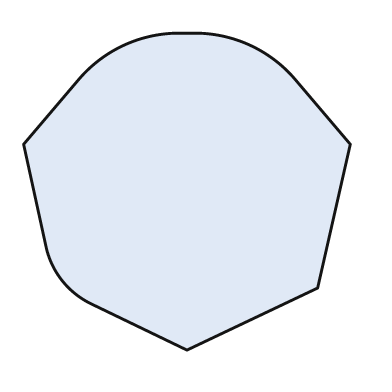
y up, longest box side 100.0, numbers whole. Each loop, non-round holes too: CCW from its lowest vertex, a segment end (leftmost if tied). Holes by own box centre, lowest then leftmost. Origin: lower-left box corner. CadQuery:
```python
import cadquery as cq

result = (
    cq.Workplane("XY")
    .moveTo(50.0, 0.0)
    .lineTo(90.0, 19.0)
    .lineTo(100.0, 63.0)
    .lineTo(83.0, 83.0)
    .threePointArc((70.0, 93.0), (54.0, 97.0))
    .lineTo(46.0, 97.0)
    .threePointArc((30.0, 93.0), (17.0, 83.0))
    .lineTo(0.0, 63.0)
    .lineTo(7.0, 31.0)
    .threePointArc((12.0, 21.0), (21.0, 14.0))
    .close()
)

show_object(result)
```